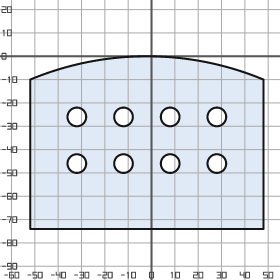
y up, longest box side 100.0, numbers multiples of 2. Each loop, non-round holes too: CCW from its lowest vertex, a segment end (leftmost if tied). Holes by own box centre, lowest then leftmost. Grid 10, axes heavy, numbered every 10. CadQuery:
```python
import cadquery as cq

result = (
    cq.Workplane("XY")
    .moveTo(-52.0, -74.0)
    .lineTo(48.0, -74.0)
    .lineTo(48.0, -10.0)
    .threePointArc((-2.0, 0.0), (-52.0, -10.0))
    .close()
    .moveTo(-32.0, -46.0)
    .circle(4.0)
    .moveTo(-12.0, -46.0)
    .circle(4.0)
    .moveTo(8.0, -46.0)
    .circle(4.0)
    .moveTo(28.0, -46.0)
    .circle(4.0)
    .moveTo(-32.0, -26.0)
    .circle(4.0)
    .moveTo(-12.0, -26.0)
    .circle(4.0)
    .moveTo(8.0, -26.0)
    .circle(4.0)
    .moveTo(28.0, -26.0)
    .circle(4.0)
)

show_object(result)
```